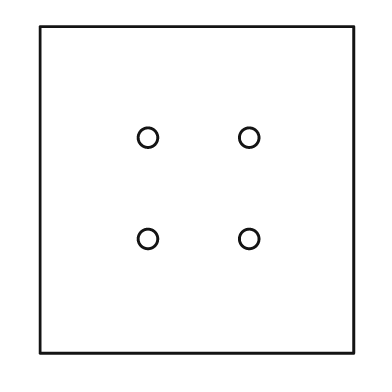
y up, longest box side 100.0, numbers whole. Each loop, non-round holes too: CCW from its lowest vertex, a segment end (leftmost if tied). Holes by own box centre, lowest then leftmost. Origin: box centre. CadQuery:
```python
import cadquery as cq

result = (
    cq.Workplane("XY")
    .moveTo(-48.0, -50.0)
    .lineTo(48.0, -50.0)
    .lineTo(48.0, 50.0)
    .lineTo(-48.0, 50.0)
    .close()
    .moveTo(-15.0, -15.0)
    .circle(3.0)
    .moveTo(16.0, -15.0)
    .circle(3.0)
    .moveTo(-15.0, 16.0)
    .circle(3.0)
    .moveTo(16.0, 16.0)
    .circle(3.0)
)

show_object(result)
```